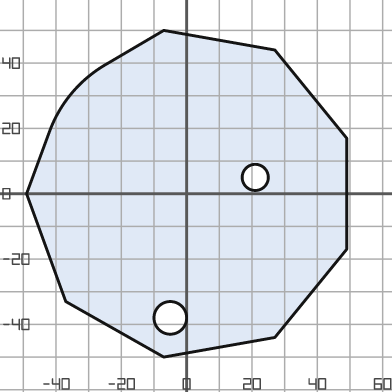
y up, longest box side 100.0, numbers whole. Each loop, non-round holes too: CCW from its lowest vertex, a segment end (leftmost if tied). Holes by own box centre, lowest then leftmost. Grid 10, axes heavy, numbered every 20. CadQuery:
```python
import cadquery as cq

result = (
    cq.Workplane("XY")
    .moveTo(-7.0, -50.0)
    .lineTo(27.0, -44.0)
    .lineTo(49.0, -17.0)
    .lineTo(49.0, 17.0)
    .lineTo(27.0, 44.0)
    .lineTo(-7.0, 50.0)
    .lineTo(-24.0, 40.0)
    .threePointArc((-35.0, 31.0), (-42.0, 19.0))
    .lineTo(-49.0, 0.0)
    .lineTo(-37.0, -33.0)
    .close()
    .moveTo(-5.0, -38.0)
    .circle(5.0)
    .moveTo(21.0, 5.0)
    .circle(4.0)
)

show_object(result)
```